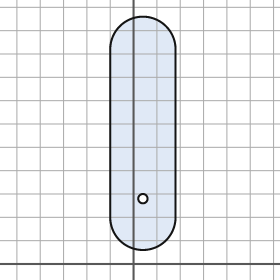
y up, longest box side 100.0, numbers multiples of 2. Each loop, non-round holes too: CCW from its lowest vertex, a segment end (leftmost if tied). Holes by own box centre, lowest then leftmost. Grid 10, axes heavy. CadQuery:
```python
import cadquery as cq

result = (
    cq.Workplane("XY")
    .moveTo(-10.0, 20.0)
    .threePointArc((4.0, 6.0), (18.0, 20.0))
    .lineTo(18.0, 92.0)
    .threePointArc((4.0, 106.0), (-10.0, 92.0))
    .close()
    .moveTo(4.0, 28.0)
    .circle(2.0)
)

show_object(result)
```